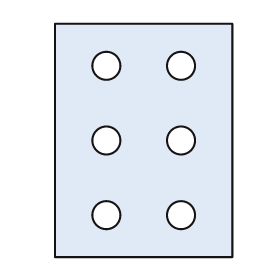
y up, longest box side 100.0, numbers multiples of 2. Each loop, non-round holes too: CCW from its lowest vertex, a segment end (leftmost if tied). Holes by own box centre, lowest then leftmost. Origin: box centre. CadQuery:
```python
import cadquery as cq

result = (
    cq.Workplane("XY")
    .moveTo(-38.0, -50.0)
    .lineTo(38.0, -50.0)
    .lineTo(38.0, 50.0)
    .lineTo(-38.0, 50.0)
    .close()
    .moveTo(-16.0, -32.0)
    .circle(6.0)
    .moveTo(16.0, -32.0)
    .circle(6.0)
    .moveTo(-16.0, 0.0)
    .circle(6.0)
    .moveTo(16.0, 0.0)
    .circle(6.0)
    .moveTo(-16.0, 32.0)
    .circle(6.0)
    .moveTo(16.0, 32.0)
    .circle(6.0)
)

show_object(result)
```